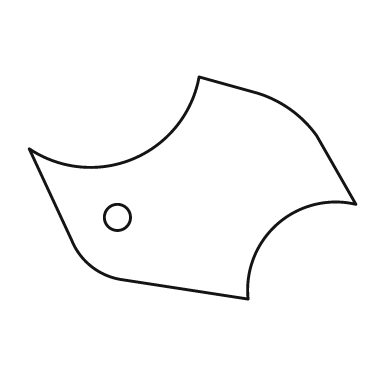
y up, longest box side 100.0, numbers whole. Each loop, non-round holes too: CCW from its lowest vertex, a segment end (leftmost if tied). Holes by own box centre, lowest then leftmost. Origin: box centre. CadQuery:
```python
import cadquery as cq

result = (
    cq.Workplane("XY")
    .moveTo(17.0, -34.0)
    .threePointArc((26.0, -11.0), (50.0, -5.0))
    .lineTo(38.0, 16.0)
    .threePointArc((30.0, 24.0), (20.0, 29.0))
    .lineTo(2.0, 34.0)
    .threePointArc((-18.0, 9.0), (-50.0, 12.0))
    .lineTo(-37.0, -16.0)
    .threePointArc((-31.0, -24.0), (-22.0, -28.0))
    .close()
    .moveTo(-23.0, -9.0)
    .circle(4.0)
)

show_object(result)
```